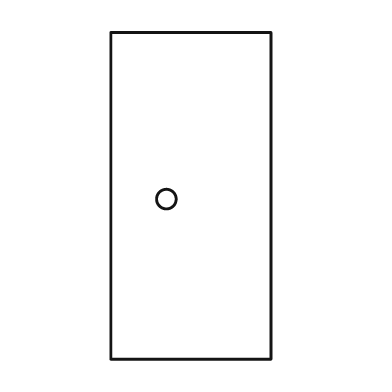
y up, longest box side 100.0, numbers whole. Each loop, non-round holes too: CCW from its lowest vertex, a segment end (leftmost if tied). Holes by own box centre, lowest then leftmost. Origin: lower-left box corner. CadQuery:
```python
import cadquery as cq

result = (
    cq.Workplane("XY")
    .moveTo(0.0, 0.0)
    .lineTo(49.0, 0.0)
    .lineTo(49.0, 100.0)
    .lineTo(0.0, 100.0)
    .close()
    .moveTo(17.0, 49.0)
    .circle(3.0)
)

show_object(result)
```